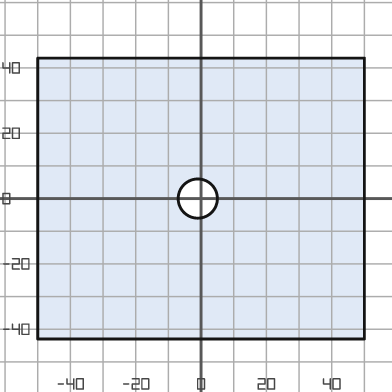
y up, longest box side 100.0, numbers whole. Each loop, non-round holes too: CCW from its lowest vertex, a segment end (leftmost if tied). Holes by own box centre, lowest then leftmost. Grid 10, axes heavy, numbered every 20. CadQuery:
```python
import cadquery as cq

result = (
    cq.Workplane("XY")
    .moveTo(-50.0, -43.0)
    .lineTo(50.0, -43.0)
    .lineTo(50.0, 43.0)
    .lineTo(-50.0, 43.0)
    .close()
    .moveTo(-1.0, 0.0)
    .circle(6.0)
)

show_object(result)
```